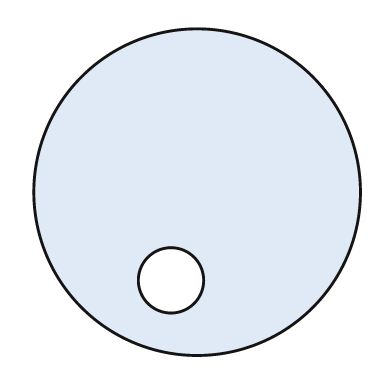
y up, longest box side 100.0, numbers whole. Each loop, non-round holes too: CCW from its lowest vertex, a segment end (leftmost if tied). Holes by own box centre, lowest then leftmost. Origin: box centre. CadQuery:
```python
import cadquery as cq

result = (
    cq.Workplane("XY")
    .moveTo(0.0, 0.0)
    .circle(50.0)
    .moveTo(-8.0, -27.0)
    .circle(10.0)
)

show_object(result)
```